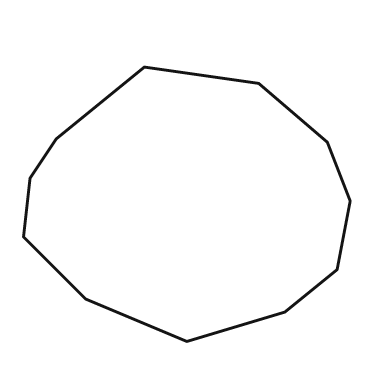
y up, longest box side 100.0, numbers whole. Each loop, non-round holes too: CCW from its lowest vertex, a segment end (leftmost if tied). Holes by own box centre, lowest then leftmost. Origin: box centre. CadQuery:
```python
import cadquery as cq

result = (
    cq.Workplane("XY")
    .moveTo(0.0, -42.0)
    .lineTo(30.0, -33.0)
    .lineTo(46.0, -20.0)
    .lineTo(50.0, 1.0)
    .lineTo(43.0, 19.0)
    .lineTo(22.0, 37.0)
    .lineTo(-13.0, 42.0)
    .lineTo(-40.0, 20.0)
    .lineTo(-48.0, 8.0)
    .lineTo(-50.0, -10.0)
    .lineTo(-31.0, -29.0)
    .close()
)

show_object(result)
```